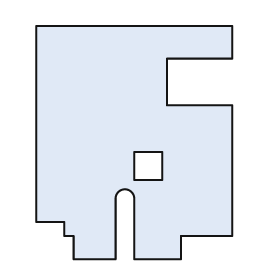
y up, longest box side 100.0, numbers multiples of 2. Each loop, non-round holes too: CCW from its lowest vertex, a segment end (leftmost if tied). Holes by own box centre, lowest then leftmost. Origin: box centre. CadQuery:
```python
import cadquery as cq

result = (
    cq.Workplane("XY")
    .moveTo(-26.0, -50.0)
    .lineTo(-8.0, -50.0)
    .lineTo(-8.0, -24.0)
    .threePointArc((-4.0, -20.0), (0.0, -24.0))
    .lineTo(0.0, -50.0)
    .lineTo(20.0, -50.0)
    .lineTo(20.0, -40.0)
    .lineTo(42.0, -40.0)
    .lineTo(42.0, 16.0)
    .lineTo(14.0, 16.0)
    .lineTo(14.0, 36.0)
    .lineTo(42.0, 36.0)
    .lineTo(42.0, 50.0)
    .lineTo(-42.0, 50.0)
    .lineTo(-42.0, -34.0)
    .lineTo(-30.0, -34.0)
    .lineTo(-30.0, -40.0)
    .lineTo(-26.0, -40.0)
    .close()
    .moveTo(0.0, -16.0)
    .lineTo(12.0, -16.0)
    .lineTo(12.0, -4.0)
    .lineTo(0.0, -4.0)
    .close()
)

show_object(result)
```